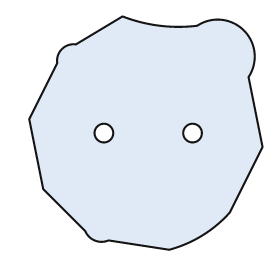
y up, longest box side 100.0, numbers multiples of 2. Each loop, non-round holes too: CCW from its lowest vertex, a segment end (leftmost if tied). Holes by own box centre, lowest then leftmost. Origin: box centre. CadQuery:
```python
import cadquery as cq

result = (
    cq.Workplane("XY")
    .moveTo(10.0, -50.0)
    .threePointArc((24.0, -44.0), (36.0, -34.0))
    .lineTo(50.0, -6.0)
    .lineTo(44.0, 24.0)
    .threePointArc((42.0, 44.0), (22.0, 46.0))
    .threePointArc((6.0, 46.0), (-10.0, 50.0))
    .lineTo(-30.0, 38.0)
    .threePointArc((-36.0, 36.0), (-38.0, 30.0))
    .lineTo(-50.0, 6.0)
    .lineTo(-44.0, -24.0)
    .lineTo(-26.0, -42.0)
    .threePointArc((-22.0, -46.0), (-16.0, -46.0))
    .close()
    .moveTo(-18.0, 0.0)
    .circle(4.0)
    .moveTo(20.0, 0.0)
    .circle(4.0)
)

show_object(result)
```